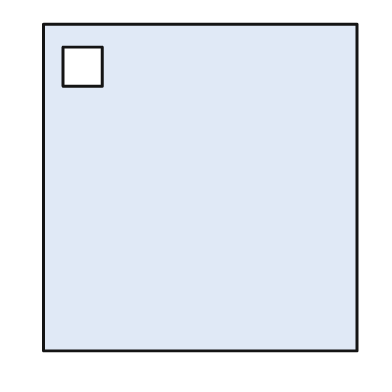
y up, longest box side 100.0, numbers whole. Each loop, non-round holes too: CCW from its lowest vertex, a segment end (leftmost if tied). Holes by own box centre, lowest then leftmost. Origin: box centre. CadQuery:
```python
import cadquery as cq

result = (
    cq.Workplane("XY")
    .moveTo(-48.0, -50.0)
    .lineTo(48.0, -50.0)
    .lineTo(48.0, 50.0)
    .lineTo(-48.0, 50.0)
    .close()
    .moveTo(-42.0, 31.0)
    .lineTo(-30.0, 31.0)
    .lineTo(-30.0, 43.0)
    .lineTo(-42.0, 43.0)
    .close()
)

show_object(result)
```